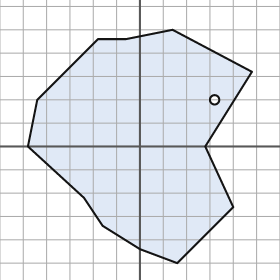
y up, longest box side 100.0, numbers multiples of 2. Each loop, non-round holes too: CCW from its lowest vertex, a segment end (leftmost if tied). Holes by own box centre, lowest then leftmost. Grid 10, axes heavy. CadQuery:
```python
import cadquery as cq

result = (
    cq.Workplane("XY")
    .moveTo(16.0, -50.0)
    .lineTo(40.0, -26.0)
    .lineTo(28.0, 0.0)
    .lineTo(48.0, 32.0)
    .lineTo(14.0, 50.0)
    .lineTo(-6.0, 46.0)
    .lineTo(-18.0, 46.0)
    .lineTo(-44.0, 20.0)
    .lineTo(-48.0, 0.0)
    .lineTo(-24.0, -22.0)
    .lineTo(-16.0, -34.0)
    .lineTo(0.0, -44.0)
    .close()
    .moveTo(32.0, 20.0)
    .circle(2.0)
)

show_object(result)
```